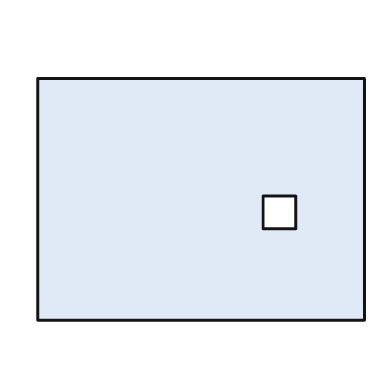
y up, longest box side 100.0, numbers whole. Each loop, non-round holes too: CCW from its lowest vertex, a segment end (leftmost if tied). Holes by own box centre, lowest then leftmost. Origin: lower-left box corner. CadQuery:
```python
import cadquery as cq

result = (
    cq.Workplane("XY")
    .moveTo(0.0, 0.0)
    .lineTo(100.0, 0.0)
    .lineTo(100.0, 74.0)
    .lineTo(0.0, 74.0)
    .close()
    .moveTo(69.0, 28.0)
    .lineTo(79.0, 28.0)
    .lineTo(79.0, 38.0)
    .lineTo(69.0, 38.0)
    .close()
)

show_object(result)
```